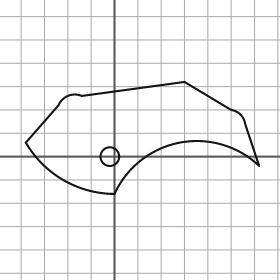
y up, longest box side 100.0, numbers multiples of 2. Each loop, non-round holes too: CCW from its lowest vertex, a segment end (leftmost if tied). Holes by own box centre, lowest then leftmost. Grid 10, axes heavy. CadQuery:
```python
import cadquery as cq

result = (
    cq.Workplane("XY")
    .moveTo(0.0, -16.0)
    .threePointArc((28.0, 6.0), (62.0, -4.0))
    .lineTo(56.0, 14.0)
    .threePointArc((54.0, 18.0), (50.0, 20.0))
    .lineTo(30.0, 32.0)
    .lineTo(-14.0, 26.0)
    .threePointArc((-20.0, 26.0), (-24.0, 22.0))
    .lineTo(-38.0, 6.0)
    .threePointArc((-22.0, -10.0), (0.0, -16.0))
    .close()
    .moveTo(-2.0, 0.0)
    .circle(4.0)
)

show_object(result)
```